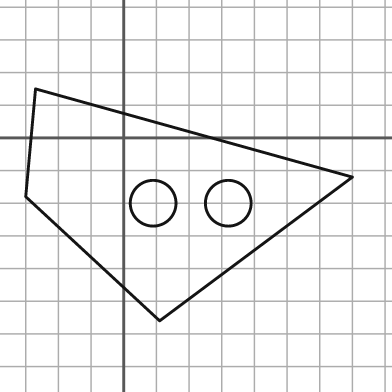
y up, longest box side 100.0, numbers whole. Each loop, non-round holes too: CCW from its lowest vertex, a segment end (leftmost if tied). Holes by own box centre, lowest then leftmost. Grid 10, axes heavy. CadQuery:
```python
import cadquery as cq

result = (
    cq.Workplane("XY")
    .moveTo(11.0, -56.0)
    .lineTo(70.0, -12.0)
    .lineTo(-27.0, 15.0)
    .lineTo(-30.0, -18.0)
    .close()
    .moveTo(9.0, -20.0)
    .circle(7.0)
    .moveTo(32.0, -20.0)
    .circle(7.0)
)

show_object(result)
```